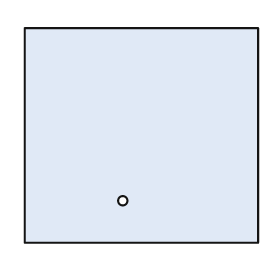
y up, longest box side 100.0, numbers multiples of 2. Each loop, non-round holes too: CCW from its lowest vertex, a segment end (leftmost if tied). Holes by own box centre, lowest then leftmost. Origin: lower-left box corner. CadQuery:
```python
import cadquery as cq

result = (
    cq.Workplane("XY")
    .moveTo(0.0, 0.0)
    .lineTo(100.0, 0.0)
    .lineTo(100.0, 92.0)
    .lineTo(0.0, 92.0)
    .close()
    .moveTo(42.0, 18.0)
    .circle(2.0)
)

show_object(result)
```